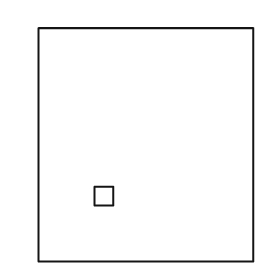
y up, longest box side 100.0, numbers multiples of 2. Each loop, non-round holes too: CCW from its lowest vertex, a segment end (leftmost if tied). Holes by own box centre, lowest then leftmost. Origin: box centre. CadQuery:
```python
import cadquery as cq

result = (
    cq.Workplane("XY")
    .moveTo(-46.0, -50.0)
    .lineTo(46.0, -50.0)
    .lineTo(46.0, 50.0)
    .lineTo(-46.0, 50.0)
    .close()
    .moveTo(-22.0, -26.0)
    .lineTo(-14.0, -26.0)
    .lineTo(-14.0, -18.0)
    .lineTo(-22.0, -18.0)
    .close()
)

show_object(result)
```